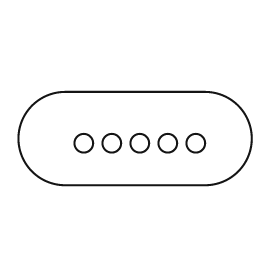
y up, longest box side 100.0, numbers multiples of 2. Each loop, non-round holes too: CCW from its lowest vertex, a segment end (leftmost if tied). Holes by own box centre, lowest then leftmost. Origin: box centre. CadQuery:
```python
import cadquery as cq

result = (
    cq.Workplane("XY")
    .moveTo(-30.0, -20.0)
    .lineTo(30.0, -20.0)
    .threePointArc((50.0, 0.0), (30.0, 20.0))
    .lineTo(-30.0, 20.0)
    .threePointArc((-50.0, 0.0), (-30.0, -20.0))
    .close()
    .moveTo(-22.0, -2.0)
    .circle(4.0)
    .moveTo(-10.0, -2.0)
    .circle(4.0)
    .moveTo(2.0, -2.0)
    .circle(4.0)
    .moveTo(14.0, -2.0)
    .circle(4.0)
    .moveTo(26.0, -2.0)
    .circle(4.0)
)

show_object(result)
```